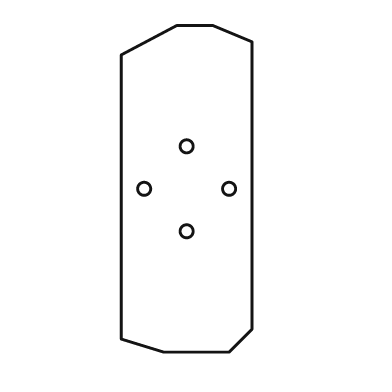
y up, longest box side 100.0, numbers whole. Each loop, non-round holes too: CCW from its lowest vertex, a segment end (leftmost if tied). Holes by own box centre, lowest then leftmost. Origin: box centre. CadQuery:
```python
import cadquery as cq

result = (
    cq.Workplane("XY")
    .moveTo(-7.0, -50.0)
    .lineTo(13.0, -50.0)
    .lineTo(20.0, -43.0)
    .lineTo(20.0, 45.0)
    .lineTo(8.0, 50.0)
    .lineTo(-3.0, 50.0)
    .lineTo(-20.0, 41.0)
    .lineTo(-20.0, -46.0)
    .close()
    .moveTo(0.0, -13.0)
    .circle(2.0)
    .moveTo(-13.0, 0.0)
    .circle(2.0)
    .moveTo(13.0, 0.0)
    .circle(2.0)
    .moveTo(0.0, 13.0)
    .circle(2.0)
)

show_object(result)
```